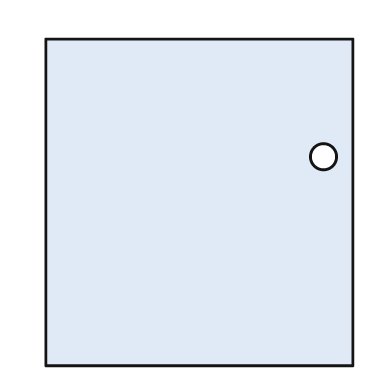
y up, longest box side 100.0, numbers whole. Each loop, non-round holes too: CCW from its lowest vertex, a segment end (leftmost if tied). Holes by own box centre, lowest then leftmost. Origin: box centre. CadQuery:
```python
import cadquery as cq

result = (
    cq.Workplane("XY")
    .moveTo(-47.0, -50.0)
    .lineTo(47.0, -50.0)
    .lineTo(47.0, 50.0)
    .lineTo(-47.0, 50.0)
    .close()
    .moveTo(38.0, 14.0)
    .circle(4.0)
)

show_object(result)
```